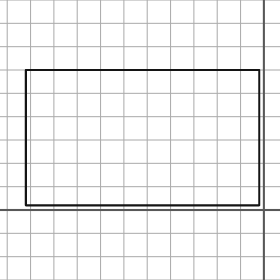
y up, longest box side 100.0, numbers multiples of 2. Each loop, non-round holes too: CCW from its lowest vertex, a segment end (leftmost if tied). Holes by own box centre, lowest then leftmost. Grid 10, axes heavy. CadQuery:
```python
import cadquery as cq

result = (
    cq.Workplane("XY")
    .moveTo(-102.0, 2.0)
    .lineTo(-2.0, 2.0)
    .lineTo(-2.0, 60.0)
    .lineTo(-102.0, 60.0)
    .close()
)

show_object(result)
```